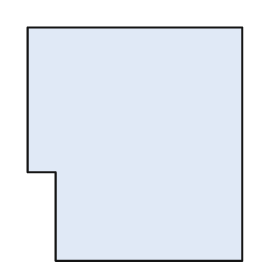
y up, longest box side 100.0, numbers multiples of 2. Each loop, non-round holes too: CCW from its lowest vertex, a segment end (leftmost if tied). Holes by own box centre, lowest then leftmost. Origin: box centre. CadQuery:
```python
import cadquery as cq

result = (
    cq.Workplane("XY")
    .moveTo(-34.0, -50.0)
    .lineTo(46.0, -50.0)
    .lineTo(46.0, 50.0)
    .lineTo(-46.0, 50.0)
    .lineTo(-46.0, -12.0)
    .lineTo(-34.0, -12.0)
    .close()
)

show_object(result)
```